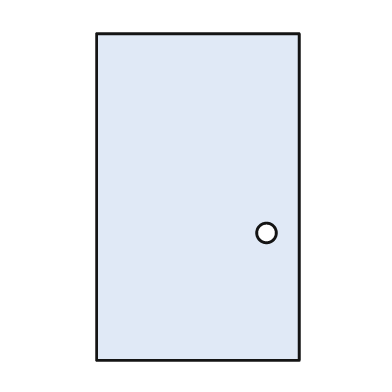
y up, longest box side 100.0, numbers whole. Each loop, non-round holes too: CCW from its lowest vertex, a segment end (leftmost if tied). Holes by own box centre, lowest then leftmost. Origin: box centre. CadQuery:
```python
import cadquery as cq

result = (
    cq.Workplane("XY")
    .moveTo(-31.0, -50.0)
    .lineTo(31.0, -50.0)
    .lineTo(31.0, 50.0)
    .lineTo(-31.0, 50.0)
    .close()
    .moveTo(21.0, -11.0)
    .circle(3.0)
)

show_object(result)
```